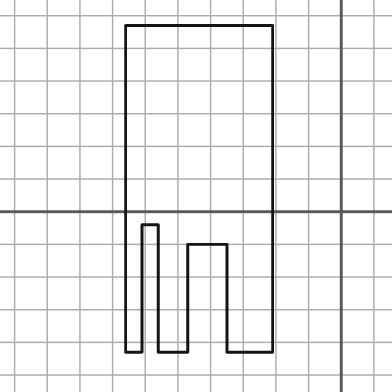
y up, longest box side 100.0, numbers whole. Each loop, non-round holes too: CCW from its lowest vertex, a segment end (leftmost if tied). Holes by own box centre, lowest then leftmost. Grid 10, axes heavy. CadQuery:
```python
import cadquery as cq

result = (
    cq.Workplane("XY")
    .moveTo(-66.0, -43.0)
    .lineTo(-61.0, -43.0)
    .lineTo(-61.0, -4.0)
    .lineTo(-56.0, -4.0)
    .lineTo(-56.0, -43.0)
    .lineTo(-47.0, -43.0)
    .lineTo(-47.0, -10.0)
    .lineTo(-35.0, -10.0)
    .lineTo(-35.0, -43.0)
    .lineTo(-21.0, -43.0)
    .lineTo(-21.0, 57.0)
    .lineTo(-66.0, 57.0)
    .close()
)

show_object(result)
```